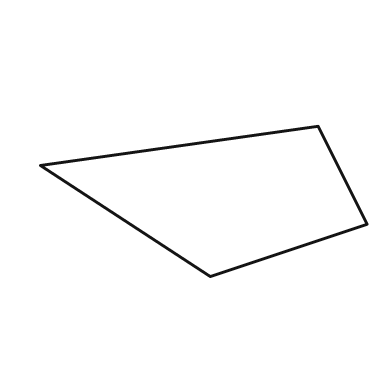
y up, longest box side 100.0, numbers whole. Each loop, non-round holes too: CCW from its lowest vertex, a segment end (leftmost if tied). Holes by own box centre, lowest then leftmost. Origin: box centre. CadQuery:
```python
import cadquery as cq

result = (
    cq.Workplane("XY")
    .moveTo(2.0, -23.0)
    .lineTo(50.0, -7.0)
    .lineTo(35.0, 23.0)
    .lineTo(-50.0, 11.0)
    .close()
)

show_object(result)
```